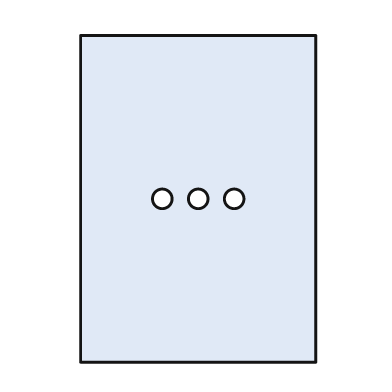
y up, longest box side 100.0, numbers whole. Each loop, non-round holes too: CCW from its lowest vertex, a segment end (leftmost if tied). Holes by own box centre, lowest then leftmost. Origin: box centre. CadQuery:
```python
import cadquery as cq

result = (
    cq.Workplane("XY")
    .moveTo(-36.0, -50.0)
    .lineTo(36.0, -50.0)
    .lineTo(36.0, 50.0)
    .lineTo(-36.0, 50.0)
    .close()
    .moveTo(-11.0, 0.0)
    .circle(3.0)
    .moveTo(0.0, 0.0)
    .circle(3.0)
    .moveTo(11.0, 0.0)
    .circle(3.0)
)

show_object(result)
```